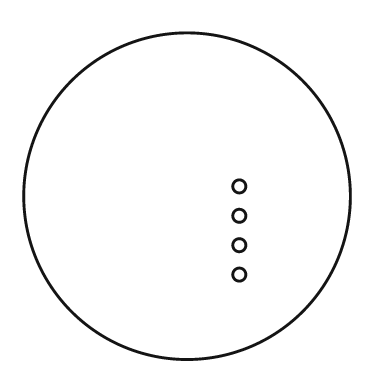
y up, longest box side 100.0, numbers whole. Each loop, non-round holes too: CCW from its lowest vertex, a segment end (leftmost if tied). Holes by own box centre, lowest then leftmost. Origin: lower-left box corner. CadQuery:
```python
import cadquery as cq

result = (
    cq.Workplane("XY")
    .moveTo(50.0, 50.0)
    .circle(50.0)
    .moveTo(66.0, 26.0)
    .circle(2.0)
    .moveTo(66.0, 35.0)
    .circle(2.0)
    .moveTo(66.0, 44.0)
    .circle(2.0)
    .moveTo(66.0, 53.0)
    .circle(2.0)
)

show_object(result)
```